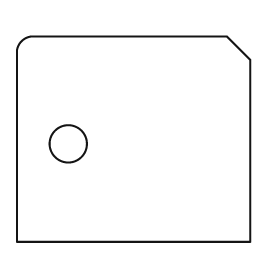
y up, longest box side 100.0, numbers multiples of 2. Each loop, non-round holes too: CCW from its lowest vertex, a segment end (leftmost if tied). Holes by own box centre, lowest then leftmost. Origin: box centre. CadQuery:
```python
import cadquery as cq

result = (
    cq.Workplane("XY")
    .moveTo(-50.0, -44.0)
    .lineTo(50.0, -44.0)
    .lineTo(50.0, 34.0)
    .lineTo(40.0, 44.0)
    .lineTo(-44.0, 44.0)
    .threePointArc((-48.0, 42.0), (-50.0, 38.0))
    .close()
    .moveTo(-28.0, -2.0)
    .circle(8.0)
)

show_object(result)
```